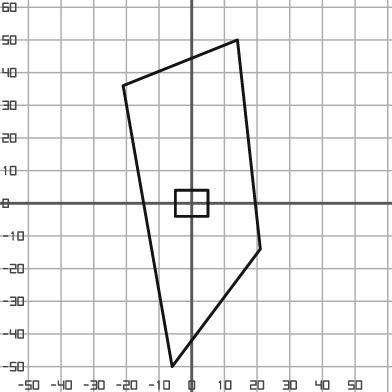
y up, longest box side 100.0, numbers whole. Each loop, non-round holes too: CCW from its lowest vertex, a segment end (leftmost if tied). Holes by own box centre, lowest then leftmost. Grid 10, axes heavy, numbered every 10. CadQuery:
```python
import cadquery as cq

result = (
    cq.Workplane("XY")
    .moveTo(-6.0, -50.0)
    .lineTo(21.0, -14.0)
    .lineTo(14.0, 50.0)
    .lineTo(-21.0, 36.0)
    .close()
    .moveTo(-5.0, -4.0)
    .lineTo(5.0, -4.0)
    .lineTo(5.0, 4.0)
    .lineTo(-5.0, 4.0)
    .close()
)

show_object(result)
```